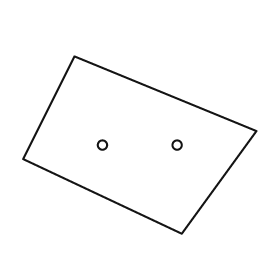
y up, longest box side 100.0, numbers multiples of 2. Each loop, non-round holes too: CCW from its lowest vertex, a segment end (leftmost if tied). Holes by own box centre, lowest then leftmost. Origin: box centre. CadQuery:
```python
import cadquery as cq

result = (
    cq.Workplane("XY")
    .moveTo(18.0, -38.0)
    .lineTo(50.0, 6.0)
    .lineTo(-28.0, 38.0)
    .lineTo(-50.0, -6.0)
    .close()
    .moveTo(-16.0, 0.0)
    .circle(2.0)
    .moveTo(16.0, 0.0)
    .circle(2.0)
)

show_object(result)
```